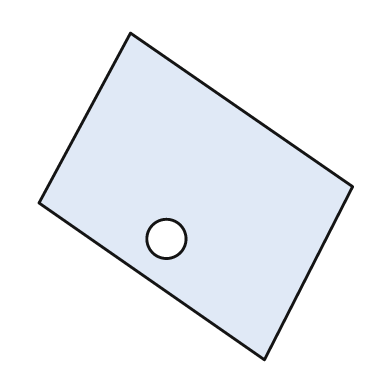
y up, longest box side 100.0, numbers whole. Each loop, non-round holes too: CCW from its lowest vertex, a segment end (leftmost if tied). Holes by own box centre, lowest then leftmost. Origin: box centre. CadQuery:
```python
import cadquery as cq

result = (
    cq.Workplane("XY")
    .moveTo(21.0, -50.0)
    .lineTo(48.0, 3.0)
    .lineTo(-20.0, 50.0)
    .lineTo(-48.0, -2.0)
    .close()
    .moveTo(-9.0, -13.0)
    .circle(6.0)
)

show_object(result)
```